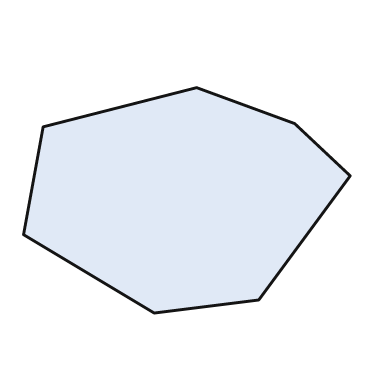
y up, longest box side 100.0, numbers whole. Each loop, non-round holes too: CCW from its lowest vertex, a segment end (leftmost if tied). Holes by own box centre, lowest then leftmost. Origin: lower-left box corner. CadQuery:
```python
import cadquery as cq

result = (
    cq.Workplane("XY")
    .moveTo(40.0, 0.0)
    .lineTo(72.0, 4.0)
    .lineTo(100.0, 42.0)
    .lineTo(83.0, 58.0)
    .lineTo(53.0, 69.0)
    .lineTo(6.0, 57.0)
    .lineTo(0.0, 24.0)
    .close()
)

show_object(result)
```